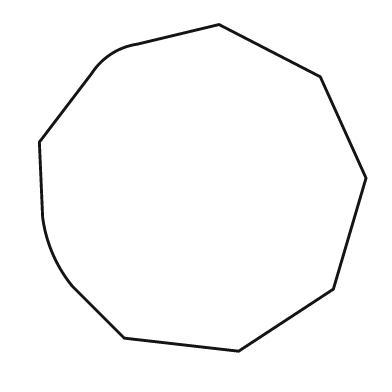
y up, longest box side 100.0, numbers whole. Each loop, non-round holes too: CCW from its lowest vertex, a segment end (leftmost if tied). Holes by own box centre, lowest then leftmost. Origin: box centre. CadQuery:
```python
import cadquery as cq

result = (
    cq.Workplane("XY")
    .moveTo(11.0, -50.0)
    .lineTo(40.0, -31.0)
    .lineTo(50.0, 3.0)
    .lineTo(36.0, 34.0)
    .lineTo(5.0, 50.0)
    .lineTo(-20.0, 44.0)
    .threePointArc((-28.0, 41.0), (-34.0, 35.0))
    .lineTo(-50.0, 14.0)
    .lineTo(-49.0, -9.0)
    .threePointArc((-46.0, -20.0), (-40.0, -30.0))
    .lineTo(-24.0, -46.0)
    .close()
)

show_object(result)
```